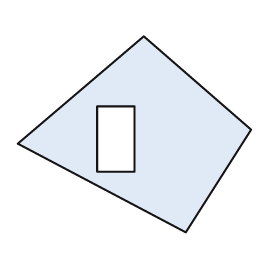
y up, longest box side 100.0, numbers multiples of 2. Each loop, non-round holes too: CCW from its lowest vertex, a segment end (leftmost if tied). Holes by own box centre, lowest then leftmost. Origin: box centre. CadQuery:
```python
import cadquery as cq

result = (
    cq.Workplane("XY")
    .moveTo(22.0, -42.0)
    .lineTo(50.0, 2.0)
    .lineTo(4.0, 42.0)
    .lineTo(-50.0, -4.0)
    .close()
    .moveTo(-16.0, -16.0)
    .lineTo(0.0, -16.0)
    .lineTo(0.0, 12.0)
    .lineTo(-16.0, 12.0)
    .close()
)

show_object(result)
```